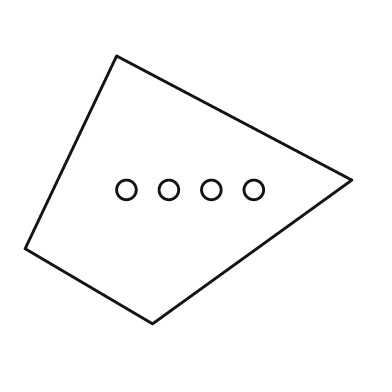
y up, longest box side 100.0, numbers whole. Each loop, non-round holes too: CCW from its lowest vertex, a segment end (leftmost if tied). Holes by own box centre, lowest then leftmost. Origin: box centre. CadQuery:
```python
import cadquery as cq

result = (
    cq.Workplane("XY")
    .moveTo(-11.0, -41.0)
    .lineTo(50.0, 3.0)
    .lineTo(-22.0, 41.0)
    .lineTo(-50.0, -18.0)
    .close()
    .moveTo(-19.0, 0.0)
    .circle(3.0)
    .moveTo(-6.0, 0.0)
    .circle(3.0)
    .moveTo(7.0, 0.0)
    .circle(3.0)
    .moveTo(20.0, 0.0)
    .circle(3.0)
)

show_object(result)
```